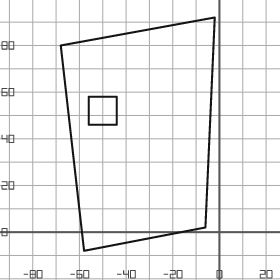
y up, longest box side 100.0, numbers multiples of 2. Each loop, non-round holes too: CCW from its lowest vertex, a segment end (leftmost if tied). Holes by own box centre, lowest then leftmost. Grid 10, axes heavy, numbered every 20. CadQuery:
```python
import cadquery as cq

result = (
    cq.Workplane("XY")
    .moveTo(-58.0, -8.0)
    .lineTo(-6.0, 2.0)
    .lineTo(-2.0, 92.0)
    .lineTo(-68.0, 80.0)
    .close()
    .moveTo(-56.0, 46.0)
    .lineTo(-44.0, 46.0)
    .lineTo(-44.0, 58.0)
    .lineTo(-56.0, 58.0)
    .close()
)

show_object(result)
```